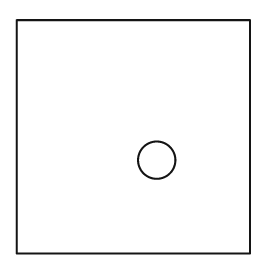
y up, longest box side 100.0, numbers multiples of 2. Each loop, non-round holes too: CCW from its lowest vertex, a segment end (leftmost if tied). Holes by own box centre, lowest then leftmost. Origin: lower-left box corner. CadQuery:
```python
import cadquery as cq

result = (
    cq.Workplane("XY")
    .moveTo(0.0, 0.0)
    .lineTo(100.0, 0.0)
    .lineTo(100.0, 100.0)
    .lineTo(0.0, 100.0)
    .close()
    .moveTo(60.0, 40.0)
    .circle(8.0)
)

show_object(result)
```